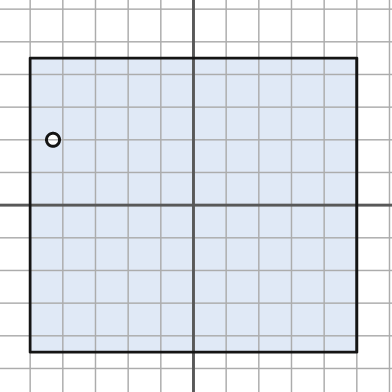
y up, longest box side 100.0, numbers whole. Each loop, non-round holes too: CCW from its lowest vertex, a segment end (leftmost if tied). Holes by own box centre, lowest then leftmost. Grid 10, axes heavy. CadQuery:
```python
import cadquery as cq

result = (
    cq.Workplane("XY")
    .moveTo(-50.0, -45.0)
    .lineTo(50.0, -45.0)
    .lineTo(50.0, 45.0)
    .lineTo(-50.0, 45.0)
    .close()
    .moveTo(-43.0, 20.0)
    .circle(2.0)
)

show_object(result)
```